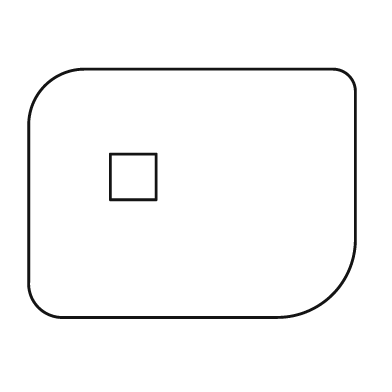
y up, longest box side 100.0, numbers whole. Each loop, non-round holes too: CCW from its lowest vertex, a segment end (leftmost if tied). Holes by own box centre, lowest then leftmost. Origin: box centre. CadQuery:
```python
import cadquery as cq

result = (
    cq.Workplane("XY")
    .moveTo(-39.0, -38.0)
    .lineTo(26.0, -38.0)
    .threePointArc((43.0, -31.0), (50.0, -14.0))
    .lineTo(50.0, 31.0)
    .threePointArc((48.0, 36.0), (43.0, 38.0))
    .lineTo(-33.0, 38.0)
    .threePointArc((-45.0, 33.0), (-50.0, 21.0))
    .lineTo(-50.0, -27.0)
    .threePointArc((-47.0, -35.0), (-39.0, -38.0))
    .close()
    .moveTo(-25.0, -2.0)
    .lineTo(-11.0, -2.0)
    .lineTo(-11.0, 12.0)
    .lineTo(-25.0, 12.0)
    .close()
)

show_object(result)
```